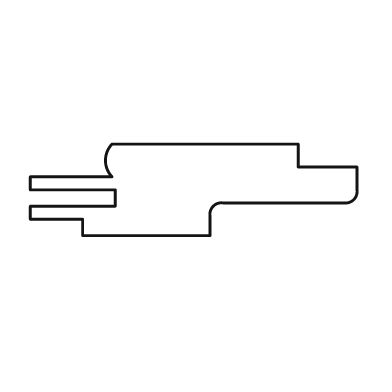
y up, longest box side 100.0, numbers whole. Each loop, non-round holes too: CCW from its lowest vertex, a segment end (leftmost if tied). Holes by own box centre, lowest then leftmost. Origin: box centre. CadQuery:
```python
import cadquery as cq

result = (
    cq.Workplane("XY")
    .moveTo(-34.0, -14.0)
    .lineTo(5.0, -14.0)
    .lineTo(5.0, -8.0)
    .threePointArc((6.0, -5.0), (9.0, -4.0))
    .lineTo(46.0, -4.0)
    .threePointArc((49.0, -3.0), (50.0, 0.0))
    .lineTo(50.0, 7.0)
    .lineTo(32.0, 7.0)
    .lineTo(32.0, 14.0)
    .lineTo(-25.0, 14.0)
    .threePointArc((-27.0, 9.0), (-25.0, 4.0))
    .lineTo(-50.0, 4.0)
    .lineTo(-50.0, 0.0)
    .lineTo(-24.0, 0.0)
    .lineTo(-24.0, -5.0)
    .lineTo(-50.0, -5.0)
    .lineTo(-50.0, -9.0)
    .lineTo(-34.0, -9.0)
    .close()
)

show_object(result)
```